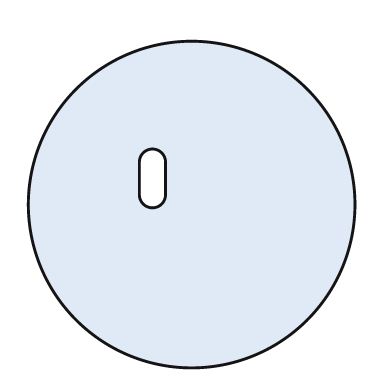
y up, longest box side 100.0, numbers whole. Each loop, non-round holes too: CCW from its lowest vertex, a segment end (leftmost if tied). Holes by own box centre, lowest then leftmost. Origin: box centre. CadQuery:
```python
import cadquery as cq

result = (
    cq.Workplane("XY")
    .moveTo(0.0, 0.0)
    .circle(50.0)
    .moveTo(-16.0, 3.0)
    .threePointArc((-12.0, -1.0), (-8.0, 3.0))
    .lineTo(-8.0, 13.0)
    .threePointArc((-12.0, 17.0), (-16.0, 13.0))
    .close()
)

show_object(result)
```